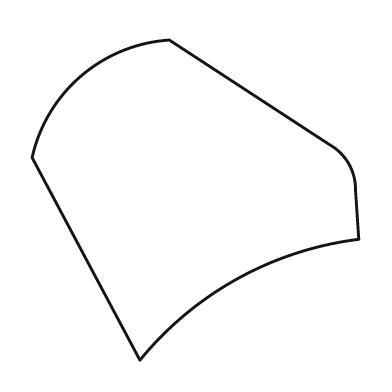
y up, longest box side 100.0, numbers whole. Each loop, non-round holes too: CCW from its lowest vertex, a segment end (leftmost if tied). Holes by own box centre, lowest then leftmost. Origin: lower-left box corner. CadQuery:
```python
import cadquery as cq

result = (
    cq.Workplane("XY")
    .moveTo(33.0, 0.0)
    .threePointArc((63.0, 25.0), (100.0, 37.0))
    .lineTo(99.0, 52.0)
    .threePointArc((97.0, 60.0), (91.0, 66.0))
    .lineTo(42.0, 98.0)
    .threePointArc((15.0, 87.0), (0.0, 62.0))
    .close()
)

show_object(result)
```